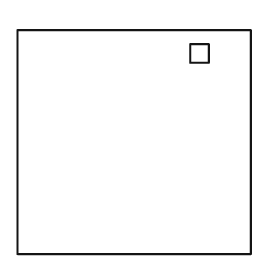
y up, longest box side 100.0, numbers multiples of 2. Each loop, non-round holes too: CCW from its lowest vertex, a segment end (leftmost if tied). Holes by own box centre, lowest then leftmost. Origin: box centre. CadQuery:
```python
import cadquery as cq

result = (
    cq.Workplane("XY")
    .moveTo(-50.0, -48.0)
    .lineTo(50.0, -48.0)
    .lineTo(50.0, 48.0)
    .lineTo(-50.0, 48.0)
    .close()
    .moveTo(24.0, 34.0)
    .lineTo(32.0, 34.0)
    .lineTo(32.0, 42.0)
    .lineTo(24.0, 42.0)
    .close()
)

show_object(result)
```